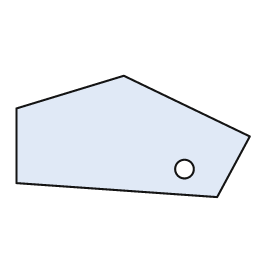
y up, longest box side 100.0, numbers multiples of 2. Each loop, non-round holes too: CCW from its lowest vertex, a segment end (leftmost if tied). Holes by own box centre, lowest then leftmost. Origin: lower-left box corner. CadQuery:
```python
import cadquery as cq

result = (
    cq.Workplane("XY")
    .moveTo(86.0, 0.0)
    .lineTo(100.0, 26.0)
    .lineTo(46.0, 52.0)
    .lineTo(0.0, 38.0)
    .lineTo(0.0, 6.0)
    .close()
    .moveTo(72.0, 12.0)
    .circle(4.0)
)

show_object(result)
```